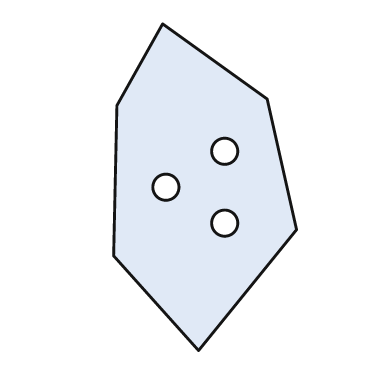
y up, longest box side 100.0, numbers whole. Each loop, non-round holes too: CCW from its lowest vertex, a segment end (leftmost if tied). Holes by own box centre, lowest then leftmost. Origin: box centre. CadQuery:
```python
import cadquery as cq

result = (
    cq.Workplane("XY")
    .moveTo(-2.0, -50.0)
    .lineTo(28.0, -13.0)
    .lineTo(19.0, 27.0)
    .lineTo(-13.0, 50.0)
    .lineTo(-27.0, 25.0)
    .lineTo(-28.0, -21.0)
    .close()
    .moveTo(6.0, -11.0)
    .circle(4.0)
    .moveTo(-12.0, 0.0)
    .circle(4.0)
    .moveTo(6.0, 11.0)
    .circle(4.0)
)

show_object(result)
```